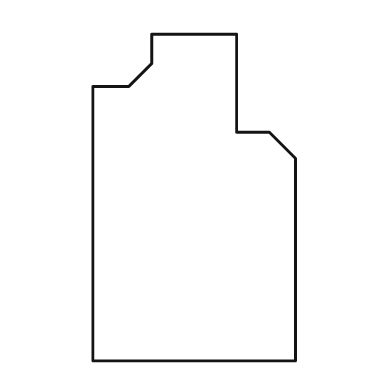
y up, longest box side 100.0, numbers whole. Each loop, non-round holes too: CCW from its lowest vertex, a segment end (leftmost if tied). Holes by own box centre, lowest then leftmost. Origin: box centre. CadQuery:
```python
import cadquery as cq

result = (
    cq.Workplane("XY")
    .moveTo(-31.0, -50.0)
    .lineTo(31.0, -50.0)
    .lineTo(31.0, 12.0)
    .lineTo(23.0, 20.0)
    .lineTo(13.0, 20.0)
    .lineTo(13.0, 50.0)
    .lineTo(-13.0, 50.0)
    .lineTo(-13.0, 41.0)
    .lineTo(-20.0, 34.0)
    .lineTo(-31.0, 34.0)
    .close()
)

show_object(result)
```